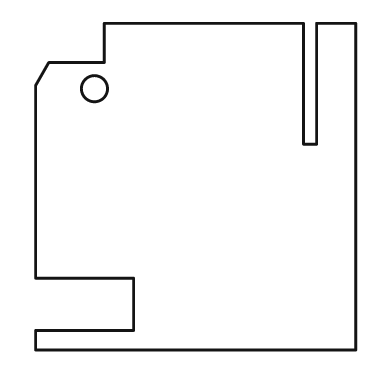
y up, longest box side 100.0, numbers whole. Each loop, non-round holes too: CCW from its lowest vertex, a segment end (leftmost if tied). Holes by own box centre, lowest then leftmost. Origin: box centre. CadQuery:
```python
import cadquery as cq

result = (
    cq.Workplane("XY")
    .moveTo(-49.0, -50.0)
    .lineTo(49.0, -50.0)
    .lineTo(49.0, 50.0)
    .lineTo(37.0, 50.0)
    .lineTo(37.0, 13.0)
    .lineTo(33.0, 13.0)
    .lineTo(33.0, 50.0)
    .lineTo(-28.0, 50.0)
    .lineTo(-28.0, 38.0)
    .lineTo(-45.0, 38.0)
    .lineTo(-49.0, 31.0)
    .lineTo(-49.0, -28.0)
    .lineTo(-19.0, -28.0)
    .lineTo(-19.0, -44.0)
    .lineTo(-49.0, -44.0)
    .close()
    .moveTo(-31.0, 30.0)
    .circle(4.0)
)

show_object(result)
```